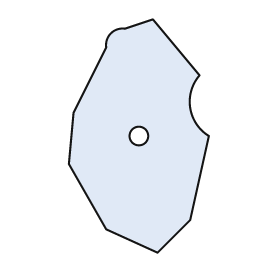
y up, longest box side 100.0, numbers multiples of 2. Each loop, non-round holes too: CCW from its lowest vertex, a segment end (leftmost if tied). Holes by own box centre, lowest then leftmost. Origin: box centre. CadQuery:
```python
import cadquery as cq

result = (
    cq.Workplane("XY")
    .moveTo(8.0, -50.0)
    .lineTo(22.0, -36.0)
    .lineTo(30.0, 0.0)
    .threePointArc((22.0, 12.0), (26.0, 26.0))
    .lineTo(6.0, 50.0)
    .lineTo(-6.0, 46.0)
    .threePointArc((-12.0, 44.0), (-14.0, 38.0))
    .lineTo(-28.0, 10.0)
    .lineTo(-30.0, -12.0)
    .lineTo(-14.0, -40.0)
    .close()
    .moveTo(0.0, 0.0)
    .circle(4.0)
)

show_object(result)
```